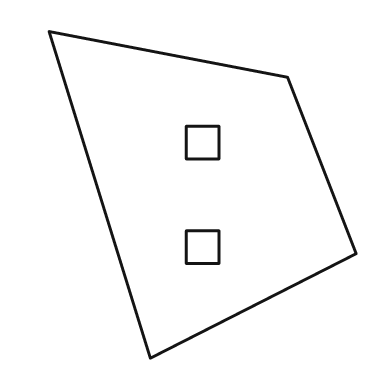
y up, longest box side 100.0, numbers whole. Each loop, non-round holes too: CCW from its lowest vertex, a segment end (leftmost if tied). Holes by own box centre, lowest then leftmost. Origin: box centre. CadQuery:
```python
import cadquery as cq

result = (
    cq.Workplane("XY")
    .moveTo(-16.0, -50.0)
    .lineTo(47.0, -18.0)
    .lineTo(26.0, 36.0)
    .lineTo(-47.0, 50.0)
    .close()
    .moveTo(-5.0, -21.0)
    .lineTo(5.0, -21.0)
    .lineTo(5.0, -11.0)
    .lineTo(-5.0, -11.0)
    .close()
    .moveTo(-5.0, 11.0)
    .lineTo(5.0, 11.0)
    .lineTo(5.0, 21.0)
    .lineTo(-5.0, 21.0)
    .close()
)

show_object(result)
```